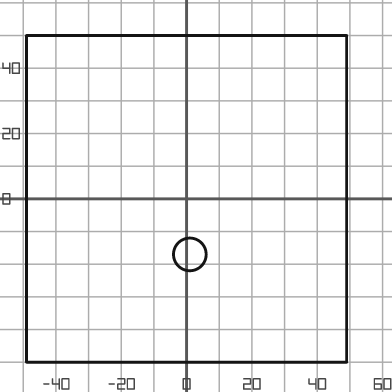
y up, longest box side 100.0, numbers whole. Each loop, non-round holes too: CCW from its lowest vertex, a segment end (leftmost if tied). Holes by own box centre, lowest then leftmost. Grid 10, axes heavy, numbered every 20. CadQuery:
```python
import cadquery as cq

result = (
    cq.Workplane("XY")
    .moveTo(-49.0, -50.0)
    .lineTo(49.0, -50.0)
    .lineTo(49.0, 50.0)
    .lineTo(-49.0, 50.0)
    .close()
    .moveTo(1.0, -17.0)
    .circle(5.0)
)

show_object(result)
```